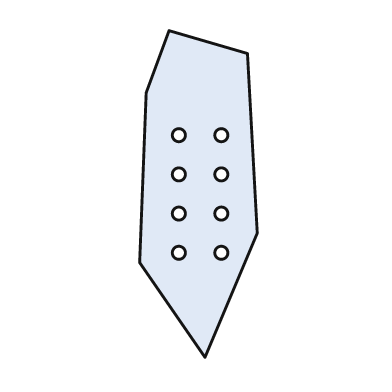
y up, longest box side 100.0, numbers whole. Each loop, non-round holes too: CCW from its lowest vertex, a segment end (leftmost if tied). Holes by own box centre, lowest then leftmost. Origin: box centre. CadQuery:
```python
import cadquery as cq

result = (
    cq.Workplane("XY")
    .moveTo(2.0, -50.0)
    .lineTo(18.0, -12.0)
    .lineTo(15.0, 43.0)
    .lineTo(-9.0, 50.0)
    .lineTo(-16.0, 31.0)
    .lineTo(-18.0, -21.0)
    .close()
    .moveTo(-6.0, -18.0)
    .circle(2.0)
    .moveTo(7.0, -18.0)
    .circle(2.0)
    .moveTo(-6.0, -6.0)
    .circle(2.0)
    .moveTo(7.0, -6.0)
    .circle(2.0)
    .moveTo(-6.0, 6.0)
    .circle(2.0)
    .moveTo(7.0, 6.0)
    .circle(2.0)
    .moveTo(-6.0, 18.0)
    .circle(2.0)
    .moveTo(7.0, 18.0)
    .circle(2.0)
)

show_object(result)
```